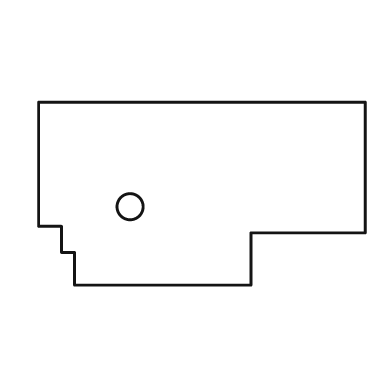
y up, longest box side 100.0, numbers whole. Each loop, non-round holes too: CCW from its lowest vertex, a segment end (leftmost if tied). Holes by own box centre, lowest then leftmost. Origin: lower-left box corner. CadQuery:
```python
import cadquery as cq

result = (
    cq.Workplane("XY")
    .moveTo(11.0, 0.0)
    .lineTo(65.0, 0.0)
    .lineTo(65.0, 16.0)
    .lineTo(100.0, 16.0)
    .lineTo(100.0, 56.0)
    .lineTo(0.0, 56.0)
    .lineTo(0.0, 18.0)
    .lineTo(7.0, 18.0)
    .lineTo(7.0, 10.0)
    .lineTo(11.0, 10.0)
    .close()
    .moveTo(28.0, 24.0)
    .circle(4.0)
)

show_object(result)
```